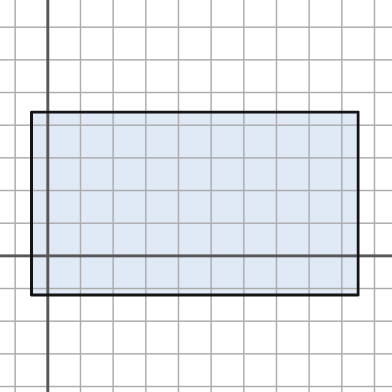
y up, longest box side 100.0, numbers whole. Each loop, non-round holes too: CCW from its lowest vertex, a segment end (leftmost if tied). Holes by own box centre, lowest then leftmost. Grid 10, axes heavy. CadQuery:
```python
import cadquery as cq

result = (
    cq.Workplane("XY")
    .moveTo(-5.0, -12.0)
    .lineTo(95.0, -12.0)
    .lineTo(95.0, 44.0)
    .lineTo(-5.0, 44.0)
    .close()
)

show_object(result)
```